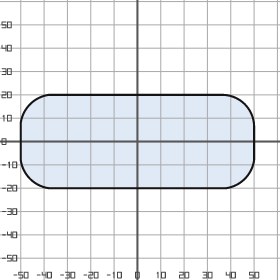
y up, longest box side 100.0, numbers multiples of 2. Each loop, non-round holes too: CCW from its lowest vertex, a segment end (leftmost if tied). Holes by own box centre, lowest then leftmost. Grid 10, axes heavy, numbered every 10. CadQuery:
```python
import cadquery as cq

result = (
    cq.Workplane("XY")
    .moveTo(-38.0, -20.0)
    .lineTo(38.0, -20.0)
    .threePointArc((46.0, -16.0), (50.0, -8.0))
    .lineTo(50.0, 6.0)
    .threePointArc((46.0, 16.0), (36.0, 20.0))
    .lineTo(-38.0, 20.0)
    .threePointArc((-46.0, 16.0), (-50.0, 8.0))
    .lineTo(-50.0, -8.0)
    .threePointArc((-46.0, -16.0), (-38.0, -20.0))
    .close()
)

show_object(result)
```